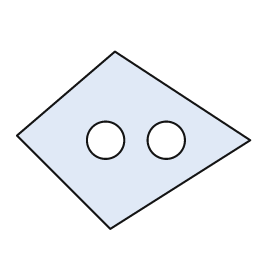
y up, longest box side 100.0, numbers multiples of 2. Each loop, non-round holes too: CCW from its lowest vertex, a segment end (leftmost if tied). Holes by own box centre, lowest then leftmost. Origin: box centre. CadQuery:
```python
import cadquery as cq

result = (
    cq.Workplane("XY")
    .moveTo(-10.0, -38.0)
    .lineTo(50.0, 0.0)
    .lineTo(-8.0, 38.0)
    .lineTo(-50.0, 2.0)
    .close()
    .moveTo(-12.0, 0.0)
    .circle(8.0)
    .moveTo(14.0, 0.0)
    .circle(8.0)
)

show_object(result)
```